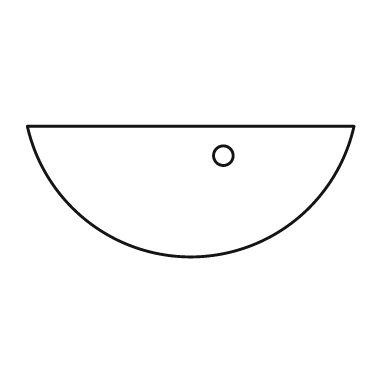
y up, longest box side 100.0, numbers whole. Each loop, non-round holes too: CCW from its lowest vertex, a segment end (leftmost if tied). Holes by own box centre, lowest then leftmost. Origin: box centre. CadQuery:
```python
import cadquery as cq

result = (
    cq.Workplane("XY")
    .moveTo(-50.0, 20.0)
    .threePointArc((0.0, -20.0), (50.0, 20.0))
    .close()
    .moveTo(10.0, 11.0)
    .circle(3.0)
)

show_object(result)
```